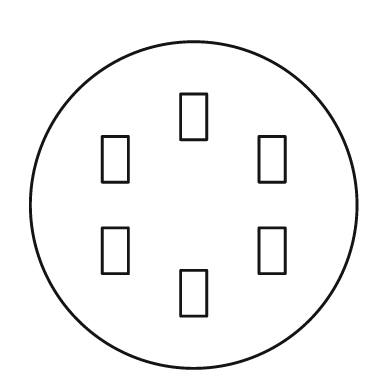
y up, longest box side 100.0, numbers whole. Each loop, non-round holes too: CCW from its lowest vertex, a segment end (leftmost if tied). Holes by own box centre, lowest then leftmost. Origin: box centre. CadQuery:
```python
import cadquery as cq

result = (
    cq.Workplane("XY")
    .moveTo(0.0, 0.0)
    .circle(50.0)
    .moveTo(-4.0, -34.0)
    .lineTo(4.0, -34.0)
    .lineTo(4.0, -20.0)
    .lineTo(-4.0, -20.0)
    .close()
    .moveTo(-28.0, -21.0)
    .lineTo(-20.0, -21.0)
    .lineTo(-20.0, -7.0)
    .lineTo(-28.0, -7.0)
    .close()
    .moveTo(20.0, -21.0)
    .lineTo(28.0, -21.0)
    .lineTo(28.0, -7.0)
    .lineTo(20.0, -7.0)
    .close()
    .moveTo(-28.0, 7.0)
    .lineTo(-20.0, 7.0)
    .lineTo(-20.0, 21.0)
    .lineTo(-28.0, 21.0)
    .close()
    .moveTo(20.0, 7.0)
    .lineTo(28.0, 7.0)
    .lineTo(28.0, 21.0)
    .lineTo(20.0, 21.0)
    .close()
    .moveTo(-4.0, 20.0)
    .lineTo(4.0, 20.0)
    .lineTo(4.0, 34.0)
    .lineTo(-4.0, 34.0)
    .close()
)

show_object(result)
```